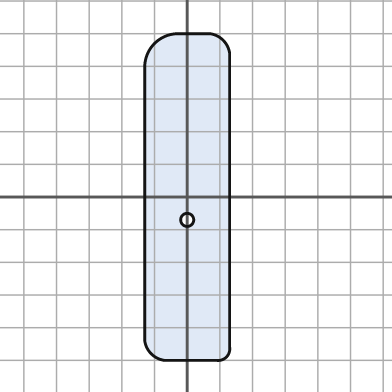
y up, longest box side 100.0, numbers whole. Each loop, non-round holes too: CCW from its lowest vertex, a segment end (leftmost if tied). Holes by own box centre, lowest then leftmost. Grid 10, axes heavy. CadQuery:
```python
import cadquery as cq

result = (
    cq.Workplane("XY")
    .moveTo(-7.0, -50.0)
    .lineTo(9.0, -50.0)
    .threePointArc((12.0, -49.0), (13.0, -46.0))
    .lineTo(13.0, 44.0)
    .threePointArc((11.0, 48.0), (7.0, 50.0))
    .lineTo(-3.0, 50.0)
    .threePointArc((-10.0, 47.0), (-13.0, 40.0))
    .lineTo(-13.0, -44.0)
    .threePointArc((-11.0, -48.0), (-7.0, -50.0))
    .close()
    .moveTo(0.0, -7.0)
    .circle(2.0)
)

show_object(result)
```